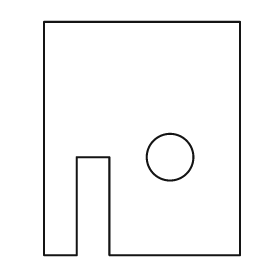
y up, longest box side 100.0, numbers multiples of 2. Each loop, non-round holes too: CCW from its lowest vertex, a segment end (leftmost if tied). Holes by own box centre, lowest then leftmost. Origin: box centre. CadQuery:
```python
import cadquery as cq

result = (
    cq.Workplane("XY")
    .moveTo(-42.0, -50.0)
    .lineTo(-28.0, -50.0)
    .lineTo(-28.0, -8.0)
    .lineTo(-14.0, -8.0)
    .lineTo(-14.0, -50.0)
    .lineTo(42.0, -50.0)
    .lineTo(42.0, 50.0)
    .lineTo(-42.0, 50.0)
    .close()
    .moveTo(12.0, -8.0)
    .circle(10.0)
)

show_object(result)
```